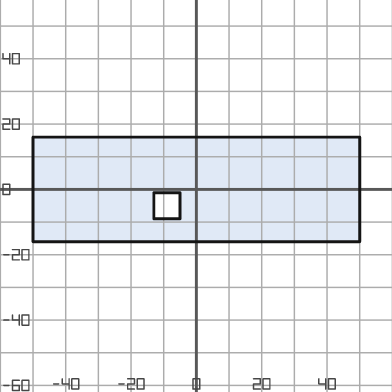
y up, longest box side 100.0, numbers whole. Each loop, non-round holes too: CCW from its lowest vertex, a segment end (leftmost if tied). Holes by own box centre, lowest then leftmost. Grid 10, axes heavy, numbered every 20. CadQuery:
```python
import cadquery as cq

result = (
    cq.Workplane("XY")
    .moveTo(-50.0, -16.0)
    .lineTo(50.0, -16.0)
    .lineTo(50.0, 16.0)
    .lineTo(-50.0, 16.0)
    .close()
    .moveTo(-13.0, -9.0)
    .lineTo(-5.0, -9.0)
    .lineTo(-5.0, -1.0)
    .lineTo(-13.0, -1.0)
    .close()
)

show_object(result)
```